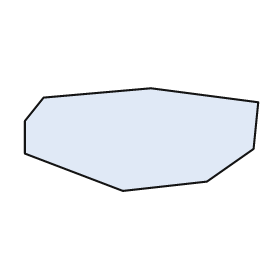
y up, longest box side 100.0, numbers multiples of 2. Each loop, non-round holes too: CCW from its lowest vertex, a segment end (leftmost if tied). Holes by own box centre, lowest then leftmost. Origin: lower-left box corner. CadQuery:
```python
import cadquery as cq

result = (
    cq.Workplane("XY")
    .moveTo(42.0, 0.0)
    .lineTo(78.0, 4.0)
    .lineTo(98.0, 18.0)
    .lineTo(100.0, 38.0)
    .lineTo(54.0, 44.0)
    .lineTo(8.0, 40.0)
    .lineTo(0.0, 30.0)
    .lineTo(0.0, 16.0)
    .close()
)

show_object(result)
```